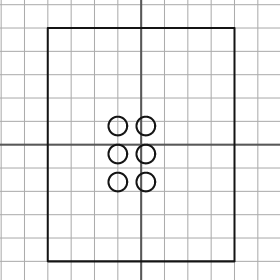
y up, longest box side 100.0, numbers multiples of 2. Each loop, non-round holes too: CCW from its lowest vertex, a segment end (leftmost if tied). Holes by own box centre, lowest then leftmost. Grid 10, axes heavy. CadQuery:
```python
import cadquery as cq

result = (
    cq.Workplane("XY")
    .moveTo(-40.0, -50.0)
    .lineTo(40.0, -50.0)
    .lineTo(40.0, 50.0)
    .lineTo(-40.0, 50.0)
    .close()
    .moveTo(-10.0, -16.0)
    .circle(4.0)
    .moveTo(2.0, -16.0)
    .circle(4.0)
    .moveTo(-10.0, -4.0)
    .circle(4.0)
    .moveTo(2.0, -4.0)
    .circle(4.0)
    .moveTo(-10.0, 8.0)
    .circle(4.0)
    .moveTo(2.0, 8.0)
    .circle(4.0)
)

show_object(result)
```